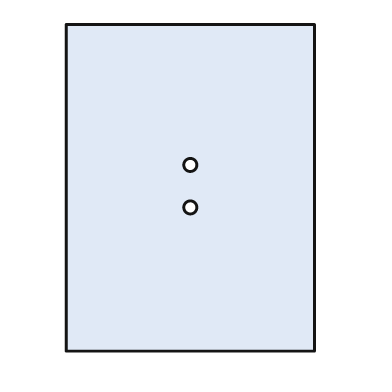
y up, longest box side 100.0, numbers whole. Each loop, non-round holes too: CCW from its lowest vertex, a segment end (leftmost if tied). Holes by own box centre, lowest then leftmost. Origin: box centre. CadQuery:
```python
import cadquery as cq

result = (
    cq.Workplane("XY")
    .moveTo(-38.0, -50.0)
    .lineTo(38.0, -50.0)
    .lineTo(38.0, 50.0)
    .lineTo(-38.0, 50.0)
    .close()
    .moveTo(0.0, -6.0)
    .circle(2.0)
    .moveTo(0.0, 7.0)
    .circle(2.0)
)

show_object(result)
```